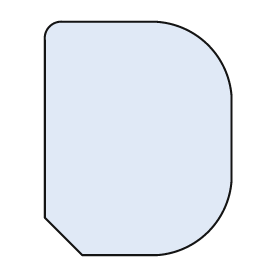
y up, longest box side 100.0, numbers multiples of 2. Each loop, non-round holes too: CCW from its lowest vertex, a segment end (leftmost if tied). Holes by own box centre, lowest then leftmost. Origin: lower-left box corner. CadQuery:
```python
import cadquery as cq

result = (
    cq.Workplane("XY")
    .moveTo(16.0, 0.0)
    .lineTo(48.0, 0.0)
    .threePointArc((70.0, 10.0), (80.0, 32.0))
    .lineTo(80.0, 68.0)
    .threePointArc((70.0, 90.0), (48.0, 100.0))
    .lineTo(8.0, 100.0)
    .threePointArc((2.0, 98.0), (0.0, 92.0))
    .lineTo(0.0, 16.0)
    .close()
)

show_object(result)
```